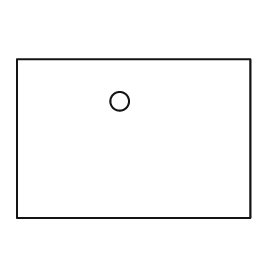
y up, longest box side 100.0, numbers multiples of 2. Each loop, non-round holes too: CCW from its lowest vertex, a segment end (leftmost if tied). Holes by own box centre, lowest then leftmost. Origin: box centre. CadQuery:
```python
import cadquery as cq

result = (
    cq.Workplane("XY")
    .moveTo(-50.0, -34.0)
    .lineTo(50.0, -34.0)
    .lineTo(50.0, 34.0)
    .lineTo(-50.0, 34.0)
    .close()
    .moveTo(-6.0, 16.0)
    .circle(4.0)
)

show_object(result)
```